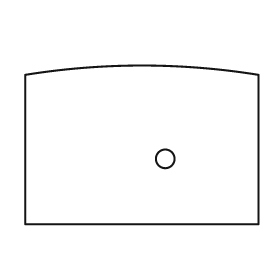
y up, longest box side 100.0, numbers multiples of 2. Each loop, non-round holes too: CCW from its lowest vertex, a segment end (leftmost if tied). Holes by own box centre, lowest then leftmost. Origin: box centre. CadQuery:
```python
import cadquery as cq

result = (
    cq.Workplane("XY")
    .moveTo(-50.0, -34.0)
    .lineTo(50.0, -34.0)
    .lineTo(50.0, 30.0)
    .threePointArc((0.0, 34.0), (-50.0, 30.0))
    .close()
    .moveTo(10.0, -6.0)
    .circle(4.0)
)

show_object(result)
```